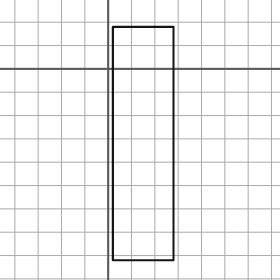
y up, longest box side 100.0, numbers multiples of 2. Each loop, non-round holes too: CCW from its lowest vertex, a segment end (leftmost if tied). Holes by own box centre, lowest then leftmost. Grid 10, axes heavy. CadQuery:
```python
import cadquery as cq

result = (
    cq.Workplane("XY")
    .moveTo(2.0, -82.0)
    .lineTo(28.0, -82.0)
    .lineTo(28.0, 18.0)
    .lineTo(2.0, 18.0)
    .close()
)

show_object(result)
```